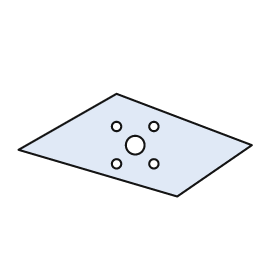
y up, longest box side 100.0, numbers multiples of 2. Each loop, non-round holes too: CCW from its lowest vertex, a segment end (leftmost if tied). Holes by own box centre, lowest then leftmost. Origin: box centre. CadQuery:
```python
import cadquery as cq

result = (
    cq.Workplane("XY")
    .moveTo(18.0, -22.0)
    .lineTo(50.0, 0.0)
    .lineTo(-8.0, 22.0)
    .lineTo(-50.0, -2.0)
    .close()
    .moveTo(-8.0, -8.0)
    .circle(2.0)
    .moveTo(8.0, -8.0)
    .circle(2.0)
    .moveTo(0.0, 0.0)
    .circle(4.0)
    .moveTo(-8.0, 8.0)
    .circle(2.0)
    .moveTo(8.0, 8.0)
    .circle(2.0)
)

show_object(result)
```